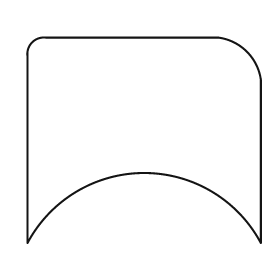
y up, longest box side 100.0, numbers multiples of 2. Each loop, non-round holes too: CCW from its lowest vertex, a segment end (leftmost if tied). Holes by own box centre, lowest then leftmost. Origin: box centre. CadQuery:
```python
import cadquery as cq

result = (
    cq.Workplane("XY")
    .moveTo(-50.0, -44.0)
    .threePointArc((0.0, -14.0), (50.0, -44.0))
    .lineTo(50.0, 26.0)
    .threePointArc((44.0, 38.0), (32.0, 44.0))
    .lineTo(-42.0, 44.0)
    .threePointArc((-48.0, 42.0), (-50.0, 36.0))
    .close()
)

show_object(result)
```